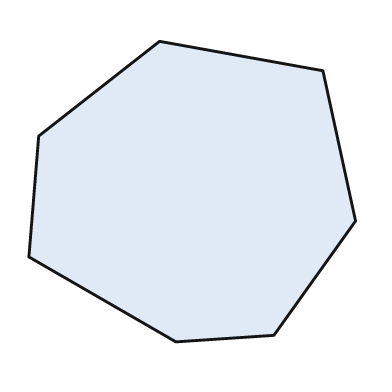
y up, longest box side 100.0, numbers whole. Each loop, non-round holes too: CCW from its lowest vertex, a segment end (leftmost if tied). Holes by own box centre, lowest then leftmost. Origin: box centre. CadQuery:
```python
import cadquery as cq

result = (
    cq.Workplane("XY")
    .moveTo(-5.0, -46.0)
    .lineTo(25.0, -44.0)
    .lineTo(50.0, -9.0)
    .lineTo(40.0, 37.0)
    .lineTo(-10.0, 46.0)
    .lineTo(-47.0, 17.0)
    .lineTo(-50.0, -20.0)
    .close()
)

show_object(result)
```